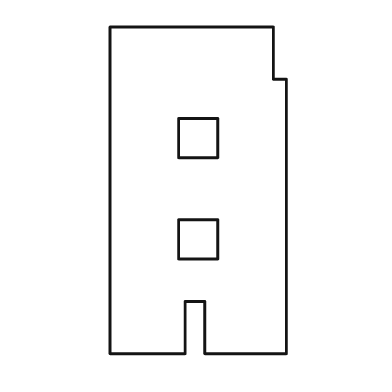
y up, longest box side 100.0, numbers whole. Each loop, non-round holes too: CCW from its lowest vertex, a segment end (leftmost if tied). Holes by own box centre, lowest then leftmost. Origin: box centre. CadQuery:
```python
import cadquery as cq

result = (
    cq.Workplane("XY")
    .moveTo(-27.0, -50.0)
    .lineTo(-4.0, -50.0)
    .lineTo(-4.0, -34.0)
    .lineTo(2.0, -34.0)
    .lineTo(2.0, -50.0)
    .lineTo(27.0, -50.0)
    .lineTo(27.0, 34.0)
    .lineTo(23.0, 34.0)
    .lineTo(23.0, 50.0)
    .lineTo(-27.0, 50.0)
    .close()
    .moveTo(-6.0, -21.0)
    .lineTo(6.0, -21.0)
    .lineTo(6.0, -9.0)
    .lineTo(-6.0, -9.0)
    .close()
    .moveTo(-6.0, 10.0)
    .lineTo(6.0, 10.0)
    .lineTo(6.0, 22.0)
    .lineTo(-6.0, 22.0)
    .close()
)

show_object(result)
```